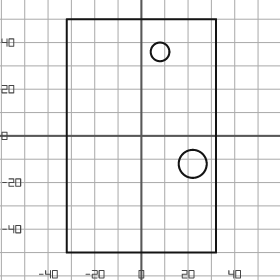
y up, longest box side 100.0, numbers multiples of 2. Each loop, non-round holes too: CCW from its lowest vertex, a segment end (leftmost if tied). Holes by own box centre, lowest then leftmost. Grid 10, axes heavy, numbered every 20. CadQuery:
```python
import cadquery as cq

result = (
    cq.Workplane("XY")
    .moveTo(-32.0, -50.0)
    .lineTo(32.0, -50.0)
    .lineTo(32.0, 50.0)
    .lineTo(-32.0, 50.0)
    .close()
    .moveTo(22.0, -12.0)
    .circle(6.0)
    .moveTo(8.0, 36.0)
    .circle(4.0)
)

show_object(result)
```